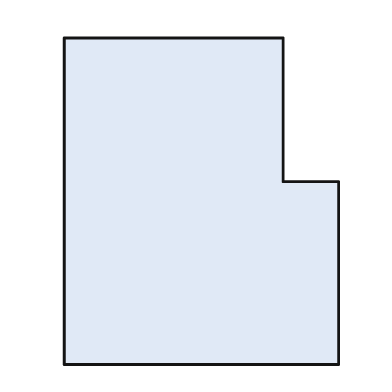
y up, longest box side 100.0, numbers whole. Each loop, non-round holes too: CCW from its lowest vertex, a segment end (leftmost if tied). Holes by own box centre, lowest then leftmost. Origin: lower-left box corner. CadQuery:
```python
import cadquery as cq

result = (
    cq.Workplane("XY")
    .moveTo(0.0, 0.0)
    .lineTo(84.0, 0.0)
    .lineTo(84.0, 56.0)
    .lineTo(67.0, 56.0)
    .lineTo(67.0, 100.0)
    .lineTo(0.0, 100.0)
    .close()
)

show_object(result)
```